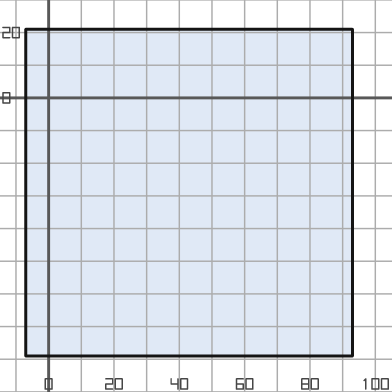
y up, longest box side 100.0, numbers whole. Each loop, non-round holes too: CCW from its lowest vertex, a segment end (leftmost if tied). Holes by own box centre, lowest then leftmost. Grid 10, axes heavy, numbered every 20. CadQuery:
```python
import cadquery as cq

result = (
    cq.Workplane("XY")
    .moveTo(-7.0, -79.0)
    .lineTo(93.0, -79.0)
    .lineTo(93.0, 21.0)
    .lineTo(-7.0, 21.0)
    .close()
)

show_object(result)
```